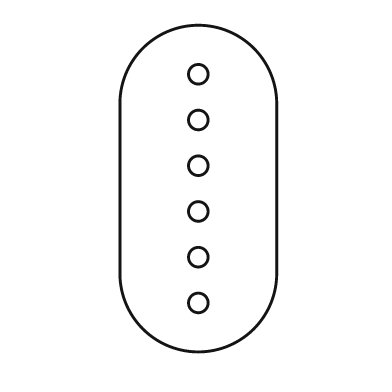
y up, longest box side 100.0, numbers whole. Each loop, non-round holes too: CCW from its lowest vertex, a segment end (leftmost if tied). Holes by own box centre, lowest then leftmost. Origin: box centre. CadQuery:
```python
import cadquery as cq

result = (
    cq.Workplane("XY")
    .moveTo(-24.0, -26.0)
    .threePointArc((0.0, -50.0), (24.0, -26.0))
    .lineTo(24.0, 26.0)
    .threePointArc((0.0, 50.0), (-24.0, 26.0))
    .close()
    .moveTo(0.0, -35.0)
    .circle(3.0)
    .moveTo(0.0, -21.0)
    .circle(3.0)
    .moveTo(0.0, -7.0)
    .circle(3.0)
    .moveTo(0.0, 7.0)
    .circle(3.0)
    .moveTo(0.0, 21.0)
    .circle(3.0)
    .moveTo(0.0, 35.0)
    .circle(3.0)
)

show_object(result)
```